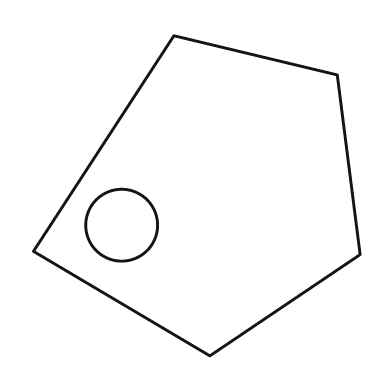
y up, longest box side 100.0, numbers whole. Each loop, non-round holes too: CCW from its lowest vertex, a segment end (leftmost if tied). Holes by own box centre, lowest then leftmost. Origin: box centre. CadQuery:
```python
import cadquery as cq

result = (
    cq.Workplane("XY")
    .moveTo(4.0, -49.0)
    .lineTo(50.0, -18.0)
    .lineTo(43.0, 37.0)
    .lineTo(-7.0, 49.0)
    .lineTo(-50.0, -17.0)
    .close()
    .moveTo(-23.0, -9.0)
    .circle(11.0)
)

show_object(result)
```